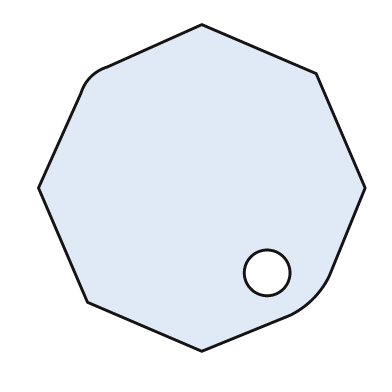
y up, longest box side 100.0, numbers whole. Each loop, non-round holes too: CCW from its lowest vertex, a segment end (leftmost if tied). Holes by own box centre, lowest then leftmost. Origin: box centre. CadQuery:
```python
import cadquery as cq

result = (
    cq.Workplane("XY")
    .moveTo(0.0, -50.0)
    .lineTo(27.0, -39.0)
    .threePointArc((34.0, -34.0), (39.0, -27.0))
    .lineTo(50.0, 0.0)
    .lineTo(35.0, 35.0)
    .lineTo(0.0, 50.0)
    .lineTo(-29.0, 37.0)
    .threePointArc((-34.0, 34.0), (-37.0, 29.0))
    .lineTo(-50.0, 0.0)
    .lineTo(-35.0, -35.0)
    .close()
    .moveTo(20.0, -26.0)
    .circle(7.0)
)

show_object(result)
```